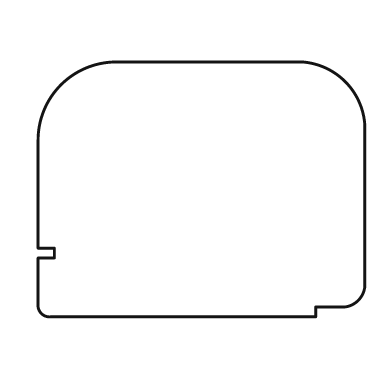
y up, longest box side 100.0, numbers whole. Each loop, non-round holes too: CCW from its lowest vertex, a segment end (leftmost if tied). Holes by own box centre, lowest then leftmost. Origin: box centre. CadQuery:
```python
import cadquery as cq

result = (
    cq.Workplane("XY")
    .moveTo(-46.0, -39.0)
    .lineTo(35.0, -39.0)
    .lineTo(35.0, -36.0)
    .lineTo(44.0, -36.0)
    .threePointArc((48.0, -34.0), (50.0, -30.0))
    .lineTo(50.0, 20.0)
    .threePointArc((44.0, 33.0), (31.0, 39.0))
    .lineTo(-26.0, 39.0)
    .threePointArc((-43.0, 32.0), (-50.0, 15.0))
    .lineTo(-50.0, -18.0)
    .lineTo(-45.0, -18.0)
    .lineTo(-45.0, -21.0)
    .lineTo(-50.0, -21.0)
    .lineTo(-50.0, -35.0)
    .threePointArc((-49.0, -38.0), (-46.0, -39.0))
    .close()
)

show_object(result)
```